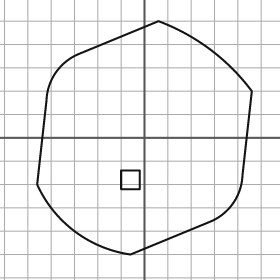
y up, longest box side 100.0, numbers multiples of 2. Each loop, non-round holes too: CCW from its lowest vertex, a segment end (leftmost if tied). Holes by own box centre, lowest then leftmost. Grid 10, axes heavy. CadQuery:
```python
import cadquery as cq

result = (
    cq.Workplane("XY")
    .moveTo(-6.0, -50.0)
    .lineTo(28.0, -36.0)
    .threePointArc((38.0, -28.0), (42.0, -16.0))
    .lineTo(46.0, 20.0)
    .threePointArc((28.0, 38.0), (6.0, 50.0))
    .lineTo(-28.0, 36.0)
    .threePointArc((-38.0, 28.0), (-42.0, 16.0))
    .lineTo(-46.0, -20.0)
    .threePointArc((-30.0, -40.0), (-6.0, -50.0))
    .close()
    .moveTo(-10.0, -22.0)
    .lineTo(-2.0, -22.0)
    .lineTo(-2.0, -14.0)
    .lineTo(-10.0, -14.0)
    .close()
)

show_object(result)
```